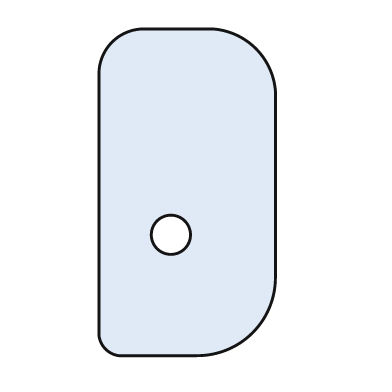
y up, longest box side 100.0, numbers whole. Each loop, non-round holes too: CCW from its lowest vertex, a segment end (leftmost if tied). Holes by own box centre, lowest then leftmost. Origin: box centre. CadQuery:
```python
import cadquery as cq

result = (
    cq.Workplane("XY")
    .moveTo(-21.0, -50.0)
    .lineTo(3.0, -50.0)
    .threePointArc((20.0, -43.0), (27.0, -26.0))
    .lineTo(27.0, 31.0)
    .threePointArc((21.0, 44.0), (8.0, 50.0))
    .lineTo(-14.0, 50.0)
    .threePointArc((-23.0, 46.0), (-27.0, 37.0))
    .lineTo(-27.0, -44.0)
    .threePointArc((-25.0, -48.0), (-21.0, -50.0))
    .close()
    .moveTo(-5.0, -13.0)
    .circle(6.0)
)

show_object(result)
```